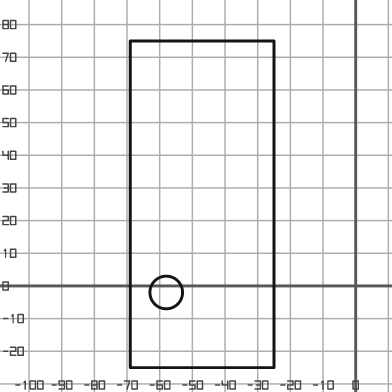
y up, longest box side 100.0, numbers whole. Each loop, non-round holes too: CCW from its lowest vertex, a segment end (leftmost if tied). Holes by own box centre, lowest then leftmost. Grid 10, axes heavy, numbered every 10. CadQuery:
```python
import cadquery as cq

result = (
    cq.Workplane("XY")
    .moveTo(-69.0, -25.0)
    .lineTo(-25.0, -25.0)
    .lineTo(-25.0, 75.0)
    .lineTo(-69.0, 75.0)
    .close()
    .moveTo(-58.0, -2.0)
    .circle(5.0)
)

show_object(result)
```